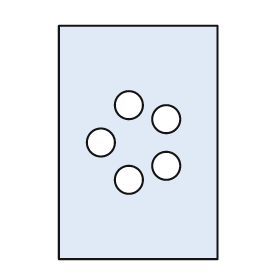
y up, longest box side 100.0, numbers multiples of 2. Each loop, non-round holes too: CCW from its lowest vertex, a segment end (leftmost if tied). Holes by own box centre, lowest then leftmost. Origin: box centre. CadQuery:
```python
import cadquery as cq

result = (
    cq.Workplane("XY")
    .moveTo(-34.0, -50.0)
    .lineTo(34.0, -50.0)
    .lineTo(34.0, 50.0)
    .lineTo(-34.0, 50.0)
    .close()
    .moveTo(-4.0, -16.0)
    .circle(6.0)
    .moveTo(12.0, -10.0)
    .circle(6.0)
    .moveTo(-16.0, 0.0)
    .circle(6.0)
    .moveTo(12.0, 10.0)
    .circle(6.0)
    .moveTo(-4.0, 16.0)
    .circle(6.0)
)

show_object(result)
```